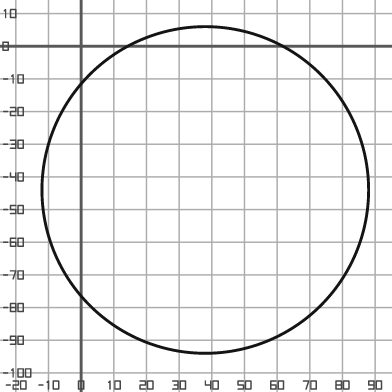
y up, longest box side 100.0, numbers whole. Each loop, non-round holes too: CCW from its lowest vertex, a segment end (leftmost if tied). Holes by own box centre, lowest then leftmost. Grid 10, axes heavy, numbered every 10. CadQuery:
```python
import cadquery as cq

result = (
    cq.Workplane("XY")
    .moveTo(38.0, -44.0)
    .circle(50.0)
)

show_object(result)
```